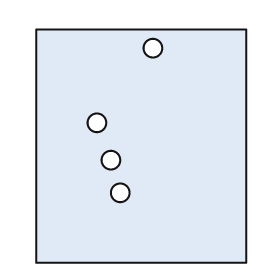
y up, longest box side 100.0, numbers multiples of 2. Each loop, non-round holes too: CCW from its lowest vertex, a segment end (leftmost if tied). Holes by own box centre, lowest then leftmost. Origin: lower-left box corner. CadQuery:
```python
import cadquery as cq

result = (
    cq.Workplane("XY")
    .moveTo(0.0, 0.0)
    .lineTo(90.0, 0.0)
    .lineTo(90.0, 100.0)
    .lineTo(0.0, 100.0)
    .close()
    .moveTo(36.0, 30.0)
    .circle(4.0)
    .moveTo(32.0, 44.0)
    .circle(4.0)
    .moveTo(26.0, 60.0)
    .circle(4.0)
    .moveTo(50.0, 92.0)
    .circle(4.0)
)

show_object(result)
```